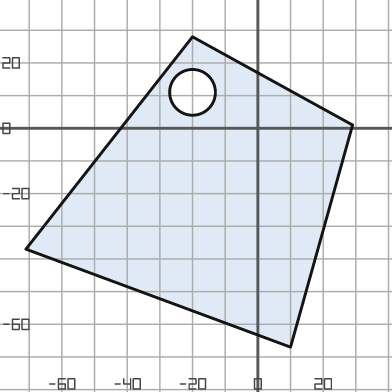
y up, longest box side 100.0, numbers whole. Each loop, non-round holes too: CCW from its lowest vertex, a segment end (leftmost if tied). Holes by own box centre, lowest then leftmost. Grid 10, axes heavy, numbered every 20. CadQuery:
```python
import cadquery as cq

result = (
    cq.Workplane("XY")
    .moveTo(10.0, -67.0)
    .lineTo(29.0, 1.0)
    .lineTo(-20.0, 28.0)
    .lineTo(-71.0, -37.0)
    .close()
    .moveTo(-20.0, 11.0)
    .circle(7.0)
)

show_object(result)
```